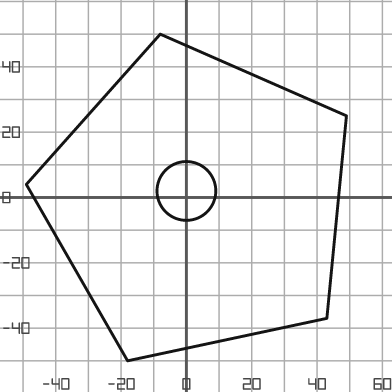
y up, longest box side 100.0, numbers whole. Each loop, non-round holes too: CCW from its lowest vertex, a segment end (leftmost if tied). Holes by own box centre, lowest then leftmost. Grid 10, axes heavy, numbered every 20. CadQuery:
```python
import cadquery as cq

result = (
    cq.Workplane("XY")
    .moveTo(-18.0, -50.0)
    .lineTo(43.0, -37.0)
    .lineTo(49.0, 25.0)
    .lineTo(-8.0, 50.0)
    .lineTo(-49.0, 4.0)
    .close()
    .moveTo(0.0, 2.0)
    .circle(9.0)
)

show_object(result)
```